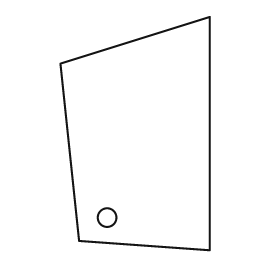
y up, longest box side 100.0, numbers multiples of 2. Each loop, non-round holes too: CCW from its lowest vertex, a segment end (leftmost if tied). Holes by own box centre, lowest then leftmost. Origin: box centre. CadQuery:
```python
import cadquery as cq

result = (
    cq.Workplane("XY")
    .moveTo(32.0, -50.0)
    .lineTo(32.0, 50.0)
    .lineTo(-32.0, 30.0)
    .lineTo(-24.0, -46.0)
    .close()
    .moveTo(-12.0, -36.0)
    .circle(4.0)
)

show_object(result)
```